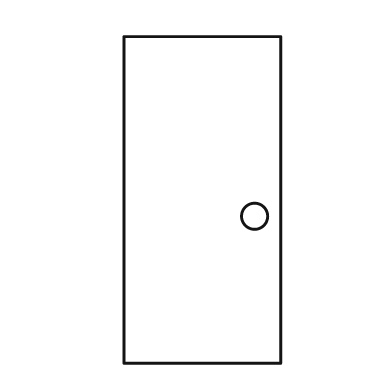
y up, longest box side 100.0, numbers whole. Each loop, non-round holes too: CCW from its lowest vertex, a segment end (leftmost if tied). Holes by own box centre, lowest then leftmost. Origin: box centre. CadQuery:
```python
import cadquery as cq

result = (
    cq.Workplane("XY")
    .moveTo(-24.0, -50.0)
    .lineTo(24.0, -50.0)
    .lineTo(24.0, 50.0)
    .lineTo(-24.0, 50.0)
    .close()
    .moveTo(16.0, -5.0)
    .circle(4.0)
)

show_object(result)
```